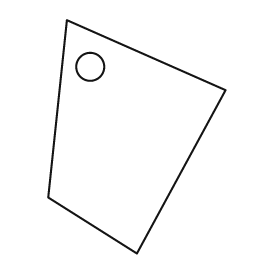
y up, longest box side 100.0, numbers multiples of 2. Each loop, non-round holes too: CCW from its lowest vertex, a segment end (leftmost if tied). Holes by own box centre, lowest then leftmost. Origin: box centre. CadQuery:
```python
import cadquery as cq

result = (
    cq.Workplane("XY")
    .moveTo(0.0, -50.0)
    .lineTo(38.0, 20.0)
    .lineTo(-30.0, 50.0)
    .lineTo(-38.0, -26.0)
    .close()
    .moveTo(-20.0, 30.0)
    .circle(6.0)
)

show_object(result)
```